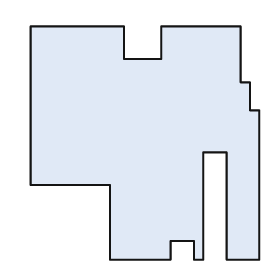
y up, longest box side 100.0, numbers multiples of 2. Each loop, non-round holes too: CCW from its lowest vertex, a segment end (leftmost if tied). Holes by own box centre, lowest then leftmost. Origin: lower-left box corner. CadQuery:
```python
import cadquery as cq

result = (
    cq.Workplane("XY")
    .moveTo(34.0, 0.0)
    .lineTo(60.0, 0.0)
    .lineTo(60.0, 8.0)
    .lineTo(70.0, 8.0)
    .lineTo(70.0, 0.0)
    .lineTo(74.0, 0.0)
    .lineTo(74.0, 46.0)
    .lineTo(84.0, 46.0)
    .lineTo(84.0, 0.0)
    .lineTo(98.0, 0.0)
    .lineTo(98.0, 64.0)
    .lineTo(94.0, 64.0)
    .lineTo(94.0, 76.0)
    .lineTo(90.0, 76.0)
    .lineTo(90.0, 100.0)
    .lineTo(56.0, 100.0)
    .lineTo(56.0, 86.0)
    .lineTo(40.0, 86.0)
    .lineTo(40.0, 100.0)
    .lineTo(0.0, 100.0)
    .lineTo(0.0, 32.0)
    .lineTo(34.0, 32.0)
    .close()
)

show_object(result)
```